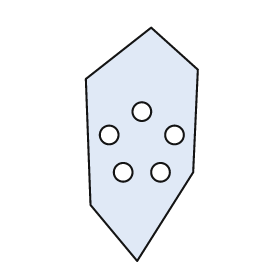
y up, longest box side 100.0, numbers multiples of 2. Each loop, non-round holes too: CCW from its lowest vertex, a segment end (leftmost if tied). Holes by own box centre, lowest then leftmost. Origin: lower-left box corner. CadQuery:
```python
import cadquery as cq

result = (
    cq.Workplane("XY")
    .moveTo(22.0, 0.0)
    .lineTo(46.0, 38.0)
    .lineTo(48.0, 82.0)
    .lineTo(28.0, 100.0)
    .lineTo(0.0, 78.0)
    .lineTo(2.0, 24.0)
    .close()
    .moveTo(16.0, 38.0)
    .circle(4.0)
    .moveTo(32.0, 38.0)
    .circle(4.0)
    .moveTo(10.0, 54.0)
    .circle(4.0)
    .moveTo(38.0, 54.0)
    .circle(4.0)
    .moveTo(24.0, 64.0)
    .circle(4.0)
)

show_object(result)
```